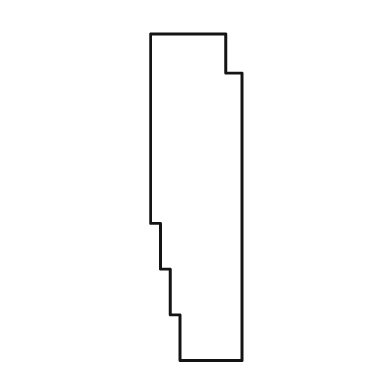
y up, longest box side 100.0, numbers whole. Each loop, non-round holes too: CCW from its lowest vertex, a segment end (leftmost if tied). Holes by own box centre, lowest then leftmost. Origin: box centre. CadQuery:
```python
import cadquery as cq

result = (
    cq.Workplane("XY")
    .moveTo(-5.0, -50.0)
    .lineTo(14.0, -50.0)
    .lineTo(14.0, 38.0)
    .lineTo(9.0, 38.0)
    .lineTo(9.0, 50.0)
    .lineTo(-14.0, 50.0)
    .lineTo(-14.0, -8.0)
    .lineTo(-11.0, -8.0)
    .lineTo(-11.0, -22.0)
    .lineTo(-8.0, -22.0)
    .lineTo(-8.0, -36.0)
    .lineTo(-5.0, -36.0)
    .close()
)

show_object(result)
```